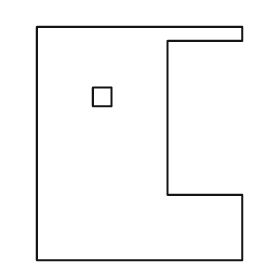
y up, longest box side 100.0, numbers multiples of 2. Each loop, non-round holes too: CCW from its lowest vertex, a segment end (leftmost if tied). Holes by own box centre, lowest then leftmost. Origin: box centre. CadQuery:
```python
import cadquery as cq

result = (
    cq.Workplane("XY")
    .moveTo(-44.0, -50.0)
    .lineTo(44.0, -50.0)
    .lineTo(44.0, -22.0)
    .lineTo(12.0, -22.0)
    .lineTo(12.0, 44.0)
    .lineTo(44.0, 44.0)
    .lineTo(44.0, 50.0)
    .lineTo(-44.0, 50.0)
    .close()
    .moveTo(-20.0, 16.0)
    .lineTo(-12.0, 16.0)
    .lineTo(-12.0, 24.0)
    .lineTo(-20.0, 24.0)
    .close()
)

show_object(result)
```